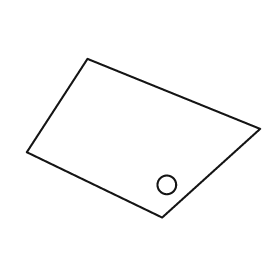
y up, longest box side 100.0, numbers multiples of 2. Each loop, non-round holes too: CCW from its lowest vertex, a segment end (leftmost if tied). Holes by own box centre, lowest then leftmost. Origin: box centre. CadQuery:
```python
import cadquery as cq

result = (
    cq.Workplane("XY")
    .moveTo(8.0, -34.0)
    .lineTo(50.0, 4.0)
    .lineTo(-24.0, 34.0)
    .lineTo(-50.0, -6.0)
    .close()
    .moveTo(10.0, -20.0)
    .circle(4.0)
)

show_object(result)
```